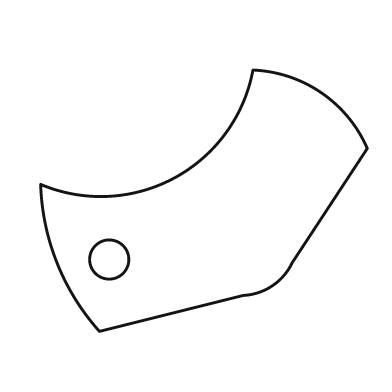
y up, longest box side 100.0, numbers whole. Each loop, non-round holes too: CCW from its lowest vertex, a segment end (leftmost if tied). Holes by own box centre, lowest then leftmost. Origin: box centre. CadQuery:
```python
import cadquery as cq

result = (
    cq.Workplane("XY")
    .moveTo(-32.0, -40.0)
    .lineTo(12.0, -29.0)
    .threePointArc((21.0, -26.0), (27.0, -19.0))
    .lineTo(50.0, 16.0)
    .threePointArc((36.0, 33.0), (15.0, 40.0))
    .threePointArc((-9.0, 7.0), (-50.0, 5.0))
    .threePointArc((-45.0, -19.0), (-32.0, -40.0))
    .close()
    .moveTo(-29.0, -18.0)
    .circle(6.0)
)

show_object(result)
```